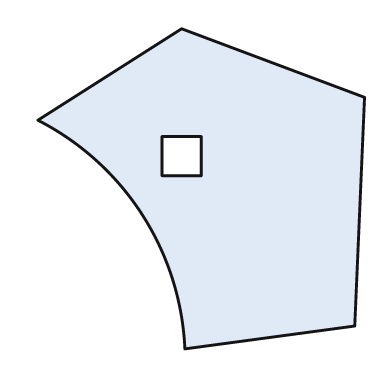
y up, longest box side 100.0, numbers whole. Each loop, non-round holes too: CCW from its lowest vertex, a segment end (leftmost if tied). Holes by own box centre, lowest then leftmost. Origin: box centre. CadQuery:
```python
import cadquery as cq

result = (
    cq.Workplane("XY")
    .moveTo(-5.0, -49.0)
    .lineTo(47.0, -42.0)
    .lineTo(50.0, 28.0)
    .lineTo(-6.0, 49.0)
    .lineTo(-50.0, 21.0)
    .threePointArc((-18.0, -8.0), (-5.0, -49.0))
    .close()
    .moveTo(-12.0, 4.0)
    .lineTo(0.0, 4.0)
    .lineTo(0.0, 16.0)
    .lineTo(-12.0, 16.0)
    .close()
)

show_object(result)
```